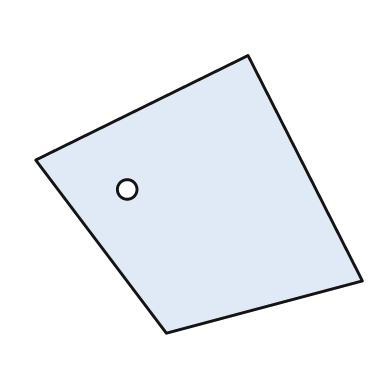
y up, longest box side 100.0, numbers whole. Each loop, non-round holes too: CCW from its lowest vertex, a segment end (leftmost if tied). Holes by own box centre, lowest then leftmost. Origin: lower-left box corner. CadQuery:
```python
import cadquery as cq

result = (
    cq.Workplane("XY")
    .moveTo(40.0, 0.0)
    .lineTo(100.0, 16.0)
    .lineTo(65.0, 85.0)
    .lineTo(0.0, 53.0)
    .close()
    .moveTo(28.0, 44.0)
    .circle(3.0)
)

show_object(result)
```